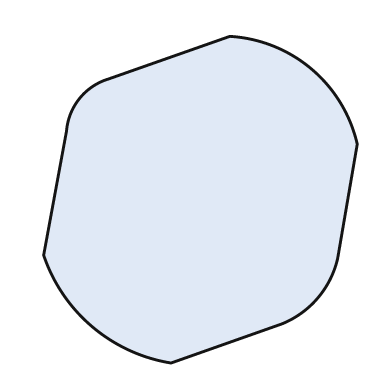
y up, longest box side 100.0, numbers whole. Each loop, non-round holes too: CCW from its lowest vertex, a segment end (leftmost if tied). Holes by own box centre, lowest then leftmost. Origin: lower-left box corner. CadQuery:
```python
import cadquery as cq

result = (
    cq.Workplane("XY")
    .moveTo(39.0, 0.0)
    .lineTo(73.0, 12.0)
    .threePointArc((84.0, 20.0), (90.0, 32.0))
    .lineTo(96.0, 67.0)
    .threePointArc((82.0, 90.0), (57.0, 100.0))
    .lineTo(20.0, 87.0)
    .threePointArc((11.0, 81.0), (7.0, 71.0))
    .lineTo(0.0, 33.0)
    .threePointArc((15.0, 11.0), (39.0, 0.0))
    .close()
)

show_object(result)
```